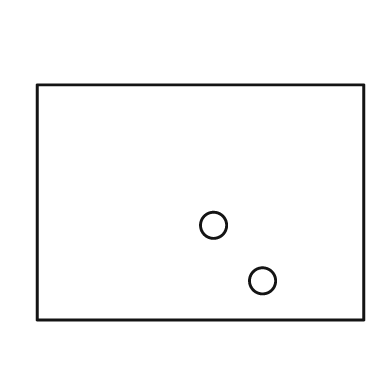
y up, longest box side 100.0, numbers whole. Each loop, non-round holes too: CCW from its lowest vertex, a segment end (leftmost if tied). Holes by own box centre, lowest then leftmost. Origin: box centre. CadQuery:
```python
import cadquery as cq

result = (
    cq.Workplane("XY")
    .moveTo(-50.0, -36.0)
    .lineTo(50.0, -36.0)
    .lineTo(50.0, 36.0)
    .lineTo(-50.0, 36.0)
    .close()
    .moveTo(19.0, -24.0)
    .circle(4.0)
    .moveTo(4.0, -7.0)
    .circle(4.0)
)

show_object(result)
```